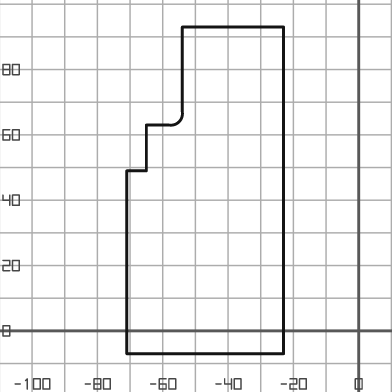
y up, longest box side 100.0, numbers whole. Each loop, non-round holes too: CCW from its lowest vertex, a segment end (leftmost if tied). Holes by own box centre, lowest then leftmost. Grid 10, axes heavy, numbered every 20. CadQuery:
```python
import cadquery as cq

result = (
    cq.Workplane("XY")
    .moveTo(-71.0, -7.0)
    .lineTo(-23.0, -7.0)
    .lineTo(-23.0, 93.0)
    .lineTo(-54.0, 93.0)
    .lineTo(-54.0, 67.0)
    .threePointArc((-55.0, 64.0), (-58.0, 63.0))
    .lineTo(-65.0, 63.0)
    .lineTo(-65.0, 49.0)
    .lineTo(-71.0, 49.0)
    .close()
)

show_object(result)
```